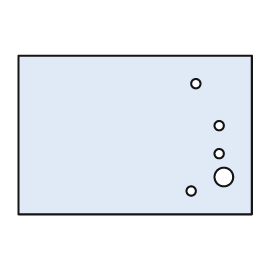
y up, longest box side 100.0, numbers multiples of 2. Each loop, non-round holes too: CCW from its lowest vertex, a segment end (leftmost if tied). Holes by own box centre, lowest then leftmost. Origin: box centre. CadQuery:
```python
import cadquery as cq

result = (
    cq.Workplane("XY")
    .moveTo(-50.0, -34.0)
    .lineTo(50.0, -34.0)
    .lineTo(50.0, 34.0)
    .lineTo(-50.0, 34.0)
    .close()
    .moveTo(24.0, -24.0)
    .circle(2.0)
    .moveTo(38.0, -18.0)
    .circle(4.0)
    .moveTo(36.0, -8.0)
    .circle(2.0)
    .moveTo(36.0, 4.0)
    .circle(2.0)
    .moveTo(26.0, 22.0)
    .circle(2.0)
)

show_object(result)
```